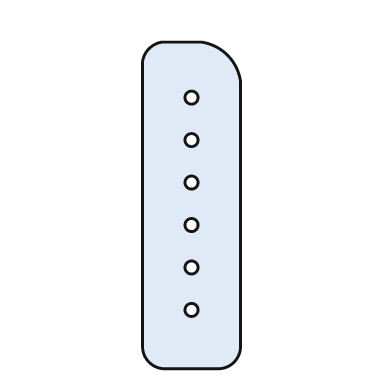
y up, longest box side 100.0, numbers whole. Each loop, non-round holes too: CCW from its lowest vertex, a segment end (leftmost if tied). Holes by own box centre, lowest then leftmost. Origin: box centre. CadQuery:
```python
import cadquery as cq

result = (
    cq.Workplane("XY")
    .moveTo(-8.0, -50.0)
    .lineTo(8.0, -50.0)
    .threePointArc((13.0, -48.0), (15.0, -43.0))
    .lineTo(15.0, 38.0)
    .threePointArc((11.0, 46.0), (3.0, 50.0))
    .lineTo(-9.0, 50.0)
    .threePointArc((-13.0, 48.0), (-15.0, 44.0))
    .lineTo(-15.0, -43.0)
    .threePointArc((-13.0, -48.0), (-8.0, -50.0))
    .close()
    .moveTo(0.0, -32.0)
    .circle(2.0)
    .moveTo(0.0, -19.0)
    .circle(2.0)
    .moveTo(0.0, -6.0)
    .circle(2.0)
    .moveTo(0.0, 7.0)
    .circle(2.0)
    .moveTo(0.0, 20.0)
    .circle(2.0)
    .moveTo(0.0, 33.0)
    .circle(2.0)
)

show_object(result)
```